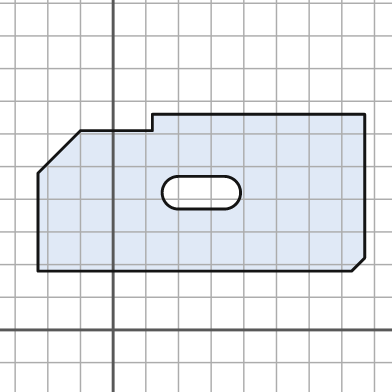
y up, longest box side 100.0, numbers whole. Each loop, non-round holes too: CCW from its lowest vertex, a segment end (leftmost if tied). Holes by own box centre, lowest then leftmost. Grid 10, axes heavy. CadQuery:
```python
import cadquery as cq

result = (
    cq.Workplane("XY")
    .moveTo(-23.0, 18.0)
    .lineTo(73.0, 18.0)
    .lineTo(77.0, 22.0)
    .lineTo(77.0, 66.0)
    .lineTo(12.0, 66.0)
    .lineTo(12.0, 61.0)
    .lineTo(-10.0, 61.0)
    .lineTo(-23.0, 48.0)
    .close()
    .moveTo(20.0, 37.0)
    .lineTo(34.0, 37.0)
    .threePointArc((39.0, 42.0), (34.0, 47.0))
    .lineTo(20.0, 47.0)
    .threePointArc((15.0, 42.0), (20.0, 37.0))
    .close()
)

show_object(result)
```